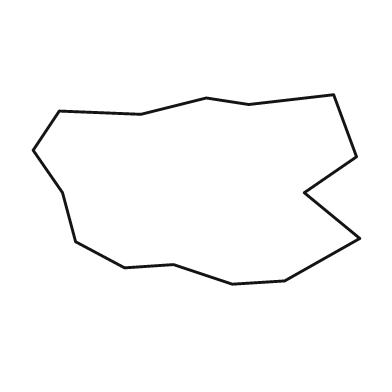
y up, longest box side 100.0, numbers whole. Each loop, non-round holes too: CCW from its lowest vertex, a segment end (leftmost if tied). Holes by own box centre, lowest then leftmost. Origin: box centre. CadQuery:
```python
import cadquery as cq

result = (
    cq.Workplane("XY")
    .moveTo(11.0, -29.0)
    .lineTo(27.0, -28.0)
    .lineTo(50.0, -15.0)
    .lineTo(33.0, -1.0)
    .lineTo(49.0, 10.0)
    .lineTo(42.0, 29.0)
    .lineTo(16.0, 26.0)
    .lineTo(3.0, 28.0)
    .lineTo(-17.0, 23.0)
    .lineTo(-42.0, 24.0)
    .lineTo(-50.0, 12.0)
    .lineTo(-41.0, -1.0)
    .lineTo(-37.0, -16.0)
    .lineTo(-22.0, -24.0)
    .lineTo(-7.0, -23.0)
    .close()
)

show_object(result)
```